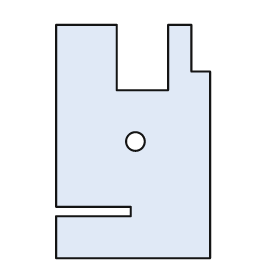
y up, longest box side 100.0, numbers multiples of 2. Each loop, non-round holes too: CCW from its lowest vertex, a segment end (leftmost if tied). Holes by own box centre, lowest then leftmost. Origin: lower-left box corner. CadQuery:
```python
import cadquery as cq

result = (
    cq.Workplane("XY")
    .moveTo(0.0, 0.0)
    .lineTo(66.0, 0.0)
    .lineTo(66.0, 80.0)
    .lineTo(58.0, 80.0)
    .lineTo(58.0, 100.0)
    .lineTo(48.0, 100.0)
    .lineTo(48.0, 72.0)
    .lineTo(26.0, 72.0)
    .lineTo(26.0, 100.0)
    .lineTo(0.0, 100.0)
    .lineTo(0.0, 22.0)
    .lineTo(32.0, 22.0)
    .lineTo(32.0, 18.0)
    .lineTo(0.0, 18.0)
    .close()
    .moveTo(34.0, 50.0)
    .circle(4.0)
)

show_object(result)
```